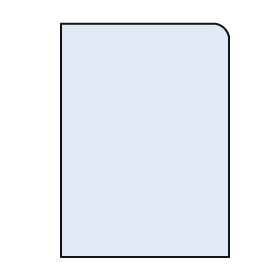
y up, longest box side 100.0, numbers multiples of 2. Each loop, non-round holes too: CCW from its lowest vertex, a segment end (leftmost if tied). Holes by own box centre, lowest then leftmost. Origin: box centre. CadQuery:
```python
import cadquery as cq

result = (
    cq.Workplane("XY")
    .moveTo(-36.0, -50.0)
    .lineTo(36.0, -50.0)
    .lineTo(36.0, 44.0)
    .threePointArc((34.0, 48.0), (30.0, 50.0))
    .lineTo(-36.0, 50.0)
    .close()
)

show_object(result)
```